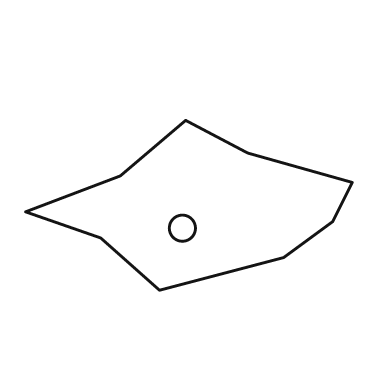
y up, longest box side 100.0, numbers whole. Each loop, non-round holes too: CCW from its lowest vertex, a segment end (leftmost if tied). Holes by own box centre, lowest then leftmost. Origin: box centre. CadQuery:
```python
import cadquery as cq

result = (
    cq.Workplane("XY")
    .moveTo(-9.0, -26.0)
    .lineTo(29.0, -16.0)
    .lineTo(44.0, -5.0)
    .lineTo(50.0, 7.0)
    .lineTo(18.0, 16.0)
    .lineTo(-1.0, 26.0)
    .lineTo(-21.0, 9.0)
    .lineTo(-50.0, -2.0)
    .lineTo(-27.0, -10.0)
    .close()
    .moveTo(-2.0, -7.0)
    .circle(4.0)
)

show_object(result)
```